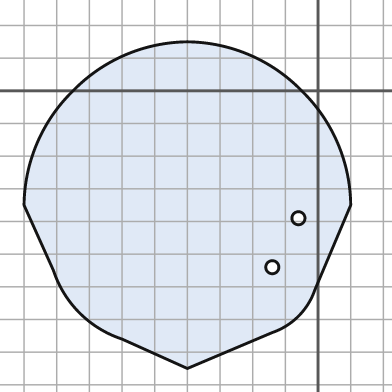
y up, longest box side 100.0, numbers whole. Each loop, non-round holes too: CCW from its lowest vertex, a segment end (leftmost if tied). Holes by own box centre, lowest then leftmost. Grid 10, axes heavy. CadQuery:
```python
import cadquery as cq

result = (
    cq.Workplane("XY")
    .moveTo(-40.0, -85.0)
    .lineTo(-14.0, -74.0)
    .threePointArc((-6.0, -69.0), (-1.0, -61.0))
    .lineTo(10.0, -35.0)
    .threePointArc((6.0, -16.0), (-5.0, 0.0))
    .threePointArc((-21.0, 11.0), (-40.0, 15.0))
    .threePointArc((-59.0, 11.0), (-75.0, 0.0))
    .threePointArc((-86.0, -16.0), (-90.0, -35.0))
    .lineTo(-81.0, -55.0)
    .threePointArc((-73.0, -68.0), (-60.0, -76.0))
    .close()
    .moveTo(-14.0, -54.0)
    .circle(2.0)
    .moveTo(-6.0, -39.0)
    .circle(2.0)
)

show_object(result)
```